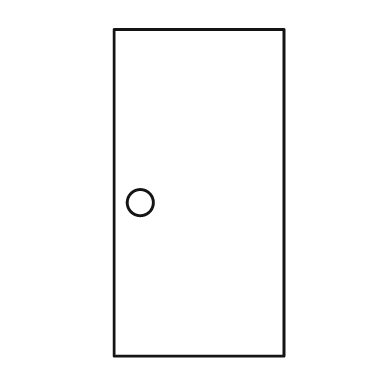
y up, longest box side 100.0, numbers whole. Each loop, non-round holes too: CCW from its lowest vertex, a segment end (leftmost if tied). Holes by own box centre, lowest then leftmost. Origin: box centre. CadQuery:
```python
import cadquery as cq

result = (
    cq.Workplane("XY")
    .moveTo(-26.0, -50.0)
    .lineTo(26.0, -50.0)
    .lineTo(26.0, 50.0)
    .lineTo(-26.0, 50.0)
    .close()
    .moveTo(-18.0, -3.0)
    .circle(4.0)
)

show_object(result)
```